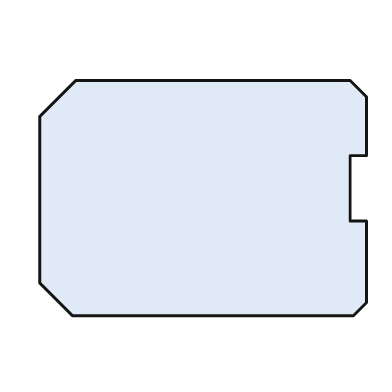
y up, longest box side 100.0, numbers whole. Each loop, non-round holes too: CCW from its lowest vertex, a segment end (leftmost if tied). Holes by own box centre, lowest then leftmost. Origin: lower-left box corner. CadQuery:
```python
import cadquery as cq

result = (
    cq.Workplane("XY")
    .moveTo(10.0, 0.0)
    .lineTo(96.0, 0.0)
    .lineTo(100.0, 4.0)
    .lineTo(100.0, 29.0)
    .lineTo(95.0, 29.0)
    .lineTo(95.0, 49.0)
    .lineTo(100.0, 49.0)
    .lineTo(100.0, 67.0)
    .lineTo(95.0, 72.0)
    .lineTo(11.0, 72.0)
    .lineTo(0.0, 61.0)
    .lineTo(0.0, 10.0)
    .close()
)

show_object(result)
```